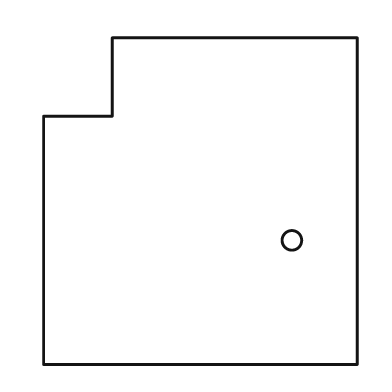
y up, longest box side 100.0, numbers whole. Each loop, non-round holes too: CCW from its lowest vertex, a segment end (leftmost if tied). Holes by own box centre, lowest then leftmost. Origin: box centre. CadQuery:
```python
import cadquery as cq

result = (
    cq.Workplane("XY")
    .moveTo(-48.0, -50.0)
    .lineTo(48.0, -50.0)
    .lineTo(48.0, 50.0)
    .lineTo(-27.0, 50.0)
    .lineTo(-27.0, 26.0)
    .lineTo(-48.0, 26.0)
    .close()
    .moveTo(28.0, -12.0)
    .circle(3.0)
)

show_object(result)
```